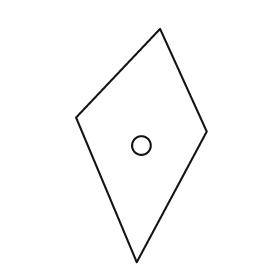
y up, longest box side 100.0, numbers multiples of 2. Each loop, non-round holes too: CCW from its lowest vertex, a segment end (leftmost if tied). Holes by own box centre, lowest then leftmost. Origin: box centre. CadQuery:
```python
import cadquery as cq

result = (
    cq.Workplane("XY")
    .moveTo(-2.0, -50.0)
    .lineTo(28.0, 6.0)
    .lineTo(8.0, 50.0)
    .lineTo(-28.0, 12.0)
    .close()
    .moveTo(0.0, 0.0)
    .circle(4.0)
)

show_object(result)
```